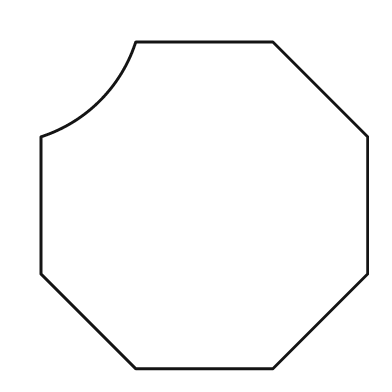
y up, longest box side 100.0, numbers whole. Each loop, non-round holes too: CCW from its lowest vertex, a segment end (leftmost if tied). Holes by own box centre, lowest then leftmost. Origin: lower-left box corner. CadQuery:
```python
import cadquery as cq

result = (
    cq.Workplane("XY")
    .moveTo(29.0, 0.0)
    .lineTo(71.0, 0.0)
    .lineTo(100.0, 29.0)
    .lineTo(100.0, 71.0)
    .lineTo(71.0, 100.0)
    .lineTo(29.0, 100.0)
    .threePointArc((18.0, 82.0), (0.0, 71.0))
    .lineTo(0.0, 29.0)
    .close()
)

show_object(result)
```